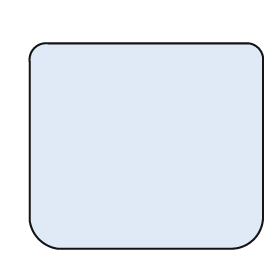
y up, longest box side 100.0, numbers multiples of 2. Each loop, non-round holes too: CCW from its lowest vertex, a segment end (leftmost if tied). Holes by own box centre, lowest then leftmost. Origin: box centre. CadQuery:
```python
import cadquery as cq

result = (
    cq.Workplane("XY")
    .moveTo(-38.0, -44.0)
    .lineTo(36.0, -44.0)
    .threePointArc((46.0, -40.0), (50.0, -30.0))
    .lineTo(50.0, 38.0)
    .threePointArc((48.0, 42.0), (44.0, 44.0))
    .lineTo(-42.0, 44.0)
    .threePointArc((-48.0, 42.0), (-50.0, 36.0))
    .lineTo(-50.0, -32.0)
    .threePointArc((-46.0, -40.0), (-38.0, -44.0))
    .close()
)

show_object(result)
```